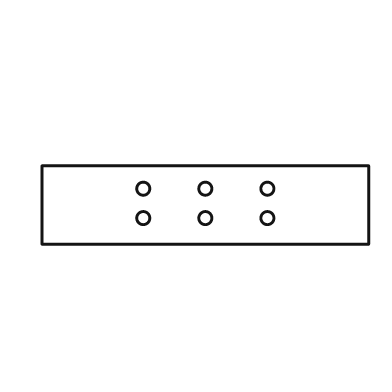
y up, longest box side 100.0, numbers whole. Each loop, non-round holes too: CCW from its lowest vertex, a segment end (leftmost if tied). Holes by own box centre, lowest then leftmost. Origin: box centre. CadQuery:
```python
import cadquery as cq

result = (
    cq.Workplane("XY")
    .moveTo(-50.0, -12.0)
    .lineTo(50.0, -12.0)
    .lineTo(50.0, 12.0)
    .lineTo(-50.0, 12.0)
    .close()
    .moveTo(-19.0, -4.0)
    .circle(2.0)
    .moveTo(0.0, -4.0)
    .circle(2.0)
    .moveTo(19.0, -4.0)
    .circle(2.0)
    .moveTo(-19.0, 5.0)
    .circle(2.0)
    .moveTo(0.0, 5.0)
    .circle(2.0)
    .moveTo(19.0, 5.0)
    .circle(2.0)
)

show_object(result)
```